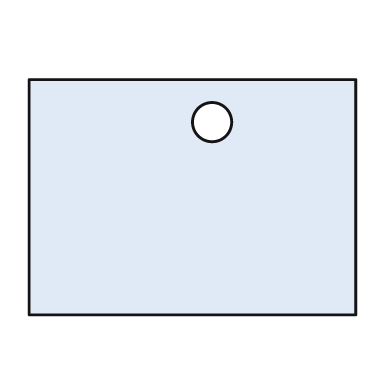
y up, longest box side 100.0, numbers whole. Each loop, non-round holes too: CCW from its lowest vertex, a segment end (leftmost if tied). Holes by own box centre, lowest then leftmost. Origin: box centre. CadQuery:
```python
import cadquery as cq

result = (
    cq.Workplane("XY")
    .moveTo(-50.0, -36.0)
    .lineTo(50.0, -36.0)
    .lineTo(50.0, 36.0)
    .lineTo(-50.0, 36.0)
    .close()
    .moveTo(6.0, 23.0)
    .circle(6.0)
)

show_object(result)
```